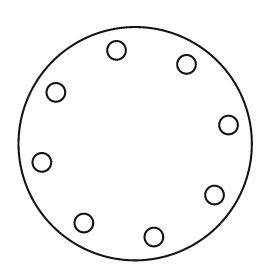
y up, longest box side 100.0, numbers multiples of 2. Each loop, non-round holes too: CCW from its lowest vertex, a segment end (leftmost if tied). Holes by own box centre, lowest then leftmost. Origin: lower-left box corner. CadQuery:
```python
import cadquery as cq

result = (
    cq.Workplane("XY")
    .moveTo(50.0, 50.0)
    .circle(50.0)
    .moveTo(58.0, 10.0)
    .circle(4.0)
    .moveTo(28.0, 16.0)
    .circle(4.0)
    .moveTo(84.0, 28.0)
    .circle(4.0)
    .moveTo(10.0, 42.0)
    .circle(4.0)
    .moveTo(90.0, 58.0)
    .circle(4.0)
    .moveTo(16.0, 72.0)
    .circle(4.0)
    .moveTo(72.0, 84.0)
    .circle(4.0)
    .moveTo(42.0, 90.0)
    .circle(4.0)
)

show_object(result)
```